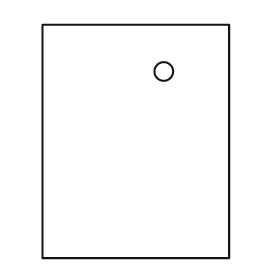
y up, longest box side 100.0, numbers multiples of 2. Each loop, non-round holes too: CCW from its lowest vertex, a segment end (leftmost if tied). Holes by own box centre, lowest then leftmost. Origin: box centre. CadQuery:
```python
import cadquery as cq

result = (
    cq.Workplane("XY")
    .moveTo(-40.0, -50.0)
    .lineTo(40.0, -50.0)
    .lineTo(40.0, 50.0)
    .lineTo(-40.0, 50.0)
    .close()
    .moveTo(12.0, 30.0)
    .circle(4.0)
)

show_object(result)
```